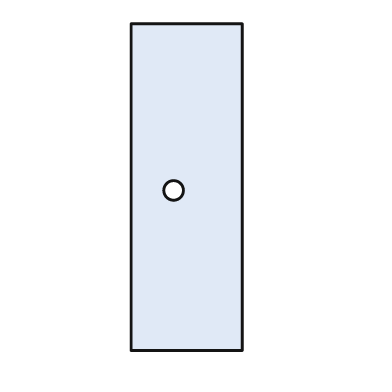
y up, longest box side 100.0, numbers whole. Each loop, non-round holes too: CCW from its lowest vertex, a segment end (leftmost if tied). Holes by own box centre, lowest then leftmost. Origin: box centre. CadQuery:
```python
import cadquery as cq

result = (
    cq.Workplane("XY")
    .moveTo(-17.0, -50.0)
    .lineTo(17.0, -50.0)
    .lineTo(17.0, 50.0)
    .lineTo(-17.0, 50.0)
    .close()
    .moveTo(-4.0, -1.0)
    .circle(3.0)
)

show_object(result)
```